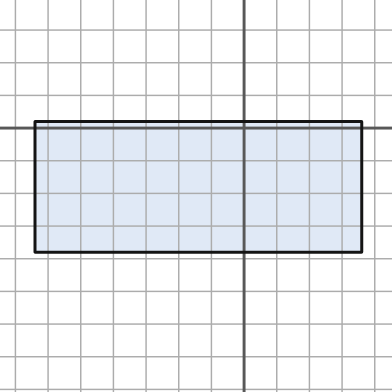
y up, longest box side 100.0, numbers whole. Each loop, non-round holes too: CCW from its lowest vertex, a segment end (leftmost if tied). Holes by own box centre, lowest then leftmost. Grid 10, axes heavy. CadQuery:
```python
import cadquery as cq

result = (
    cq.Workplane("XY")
    .moveTo(-64.0, -38.0)
    .lineTo(36.0, -38.0)
    .lineTo(36.0, 2.0)
    .lineTo(-64.0, 2.0)
    .close()
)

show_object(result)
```